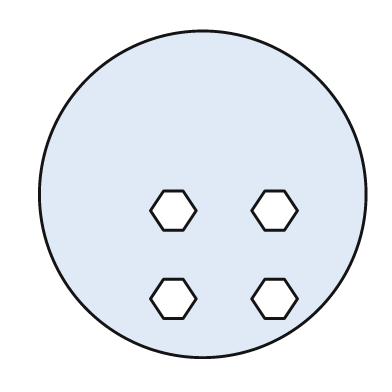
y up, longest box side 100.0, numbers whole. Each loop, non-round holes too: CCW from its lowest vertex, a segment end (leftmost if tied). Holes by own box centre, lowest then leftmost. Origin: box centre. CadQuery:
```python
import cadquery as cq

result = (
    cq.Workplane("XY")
    .moveTo(0.0, 0.0)
    .circle(50.0)
    .moveTo(-12.0, -38.0)
    .lineTo(-6.0, -38.0)
    .lineTo(-2.0, -32.0)
    .lineTo(-6.0, -26.0)
    .lineTo(-12.0, -26.0)
    .lineTo(-16.0, -32.0)
    .close()
    .moveTo(19.0, -38.0)
    .lineTo(25.0, -38.0)
    .lineTo(29.0, -32.0)
    .lineTo(25.0, -26.0)
    .lineTo(19.0, -26.0)
    .lineTo(15.0, -32.0)
    .close()
    .moveTo(-12.0, -11.0)
    .lineTo(-6.0, -11.0)
    .lineTo(-2.0, -5.0)
    .lineTo(-6.0, 1.0)
    .lineTo(-12.0, 1.0)
    .lineTo(-16.0, -5.0)
    .close()
    .moveTo(19.0, -11.0)
    .lineTo(25.0, -11.0)
    .lineTo(29.0, -5.0)
    .lineTo(25.0, 1.0)
    .lineTo(19.0, 1.0)
    .lineTo(15.0, -5.0)
    .close()
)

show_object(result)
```